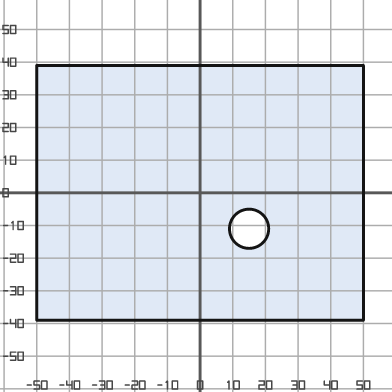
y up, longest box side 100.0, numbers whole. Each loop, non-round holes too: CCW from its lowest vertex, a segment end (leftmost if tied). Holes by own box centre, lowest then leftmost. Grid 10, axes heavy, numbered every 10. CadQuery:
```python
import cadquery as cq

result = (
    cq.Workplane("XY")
    .moveTo(-50.0, -39.0)
    .lineTo(50.0, -39.0)
    .lineTo(50.0, 39.0)
    .lineTo(-50.0, 39.0)
    .close()
    .moveTo(15.0, -11.0)
    .circle(6.0)
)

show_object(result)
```